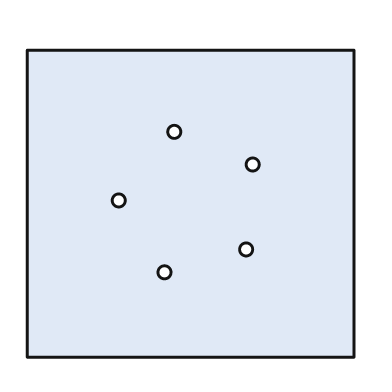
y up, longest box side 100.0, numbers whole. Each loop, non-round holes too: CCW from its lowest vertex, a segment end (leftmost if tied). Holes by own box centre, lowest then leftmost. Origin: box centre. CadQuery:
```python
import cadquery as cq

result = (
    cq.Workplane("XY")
    .moveTo(-50.0, -47.0)
    .lineTo(50.0, -47.0)
    .lineTo(50.0, 47.0)
    .lineTo(-50.0, 47.0)
    .close()
    .moveTo(-8.0, -21.0)
    .circle(2.0)
    .moveTo(17.0, -14.0)
    .circle(2.0)
    .moveTo(-22.0, 1.0)
    .circle(2.0)
    .moveTo(19.0, 12.0)
    .circle(2.0)
    .moveTo(-5.0, 22.0)
    .circle(2.0)
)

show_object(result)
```